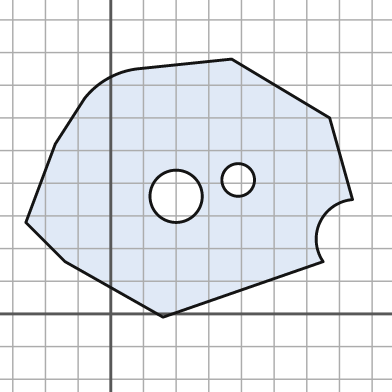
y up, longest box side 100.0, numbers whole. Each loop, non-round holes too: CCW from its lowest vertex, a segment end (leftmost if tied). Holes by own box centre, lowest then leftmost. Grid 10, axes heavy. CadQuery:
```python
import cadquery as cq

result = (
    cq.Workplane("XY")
    .moveTo(16.0, -1.0)
    .lineTo(65.0, 16.0)
    .threePointArc((64.0, 28.0), (74.0, 35.0))
    .lineTo(67.0, 60.0)
    .lineTo(37.0, 78.0)
    .lineTo(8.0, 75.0)
    .threePointArc((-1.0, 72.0), (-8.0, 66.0))
    .lineTo(-17.0, 52.0)
    .lineTo(-26.0, 28.0)
    .lineTo(-14.0, 16.0)
    .close()
    .moveTo(20.0, 36.0)
    .circle(8.0)
    .moveTo(39.0, 41.0)
    .circle(5.0)
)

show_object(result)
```